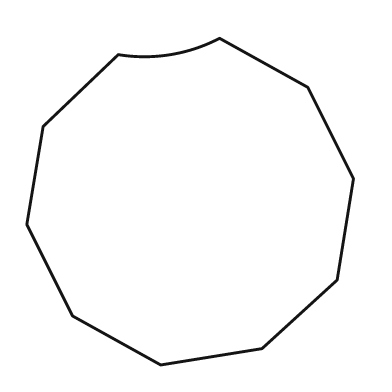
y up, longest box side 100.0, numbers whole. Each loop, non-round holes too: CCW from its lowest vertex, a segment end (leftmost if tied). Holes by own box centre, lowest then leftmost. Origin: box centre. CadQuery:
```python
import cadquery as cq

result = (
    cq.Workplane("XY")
    .moveTo(-9.0, -50.0)
    .lineTo(22.0, -45.0)
    .lineTo(45.0, -24.0)
    .lineTo(50.0, 7.0)
    .lineTo(36.0, 35.0)
    .lineTo(9.0, 50.0)
    .threePointArc((-6.0, 45.0), (-22.0, 45.0))
    .lineTo(-45.0, 23.0)
    .lineTo(-50.0, -7.0)
    .lineTo(-36.0, -35.0)
    .close()
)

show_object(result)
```